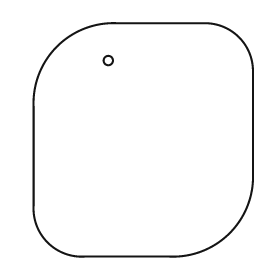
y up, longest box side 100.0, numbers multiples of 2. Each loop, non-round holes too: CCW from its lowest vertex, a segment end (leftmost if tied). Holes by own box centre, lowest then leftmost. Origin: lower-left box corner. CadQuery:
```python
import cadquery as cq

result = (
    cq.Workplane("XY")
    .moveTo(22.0, 0.0)
    .lineTo(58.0, 0.0)
    .threePointArc((84.0, 10.0), (94.0, 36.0))
    .lineTo(94.0, 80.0)
    .threePointArc((88.0, 94.0), (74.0, 100.0))
    .lineTo(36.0, 100.0)
    .threePointArc((10.0, 90.0), (0.0, 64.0))
    .lineTo(0.0, 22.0)
    .threePointArc((6.0, 6.0), (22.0, 0.0))
    .close()
    .moveTo(32.0, 84.0)
    .circle(2.0)
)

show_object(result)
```